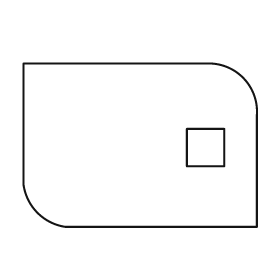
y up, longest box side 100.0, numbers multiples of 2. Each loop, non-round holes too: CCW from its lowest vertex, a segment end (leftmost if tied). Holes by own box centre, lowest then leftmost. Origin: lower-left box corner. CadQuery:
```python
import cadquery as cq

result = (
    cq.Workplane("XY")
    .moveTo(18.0, 0.0)
    .lineTo(100.0, 0.0)
    .lineTo(100.0, 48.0)
    .threePointArc((94.0, 64.0), (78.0, 70.0))
    .lineTo(0.0, 70.0)
    .lineTo(0.0, 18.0)
    .threePointArc((6.0, 6.0), (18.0, 0.0))
    .close()
    .moveTo(70.0, 26.0)
    .lineTo(86.0, 26.0)
    .lineTo(86.0, 42.0)
    .lineTo(70.0, 42.0)
    .close()
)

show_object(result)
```